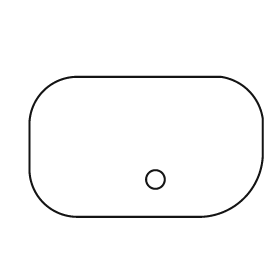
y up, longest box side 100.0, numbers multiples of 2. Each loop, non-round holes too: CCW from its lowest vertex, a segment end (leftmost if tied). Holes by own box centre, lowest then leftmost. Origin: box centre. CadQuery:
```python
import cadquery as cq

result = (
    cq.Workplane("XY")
    .moveTo(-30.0, -30.0)
    .lineTo(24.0, -30.0)
    .threePointArc((42.0, -22.0), (50.0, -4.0))
    .lineTo(50.0, 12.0)
    .threePointArc((44.0, 24.0), (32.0, 30.0))
    .lineTo(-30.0, 30.0)
    .threePointArc((-44.0, 24.0), (-50.0, 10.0))
    .lineTo(-50.0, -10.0)
    .threePointArc((-44.0, -24.0), (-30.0, -30.0))
    .close()
    .moveTo(4.0, -14.0)
    .circle(4.0)
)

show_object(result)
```